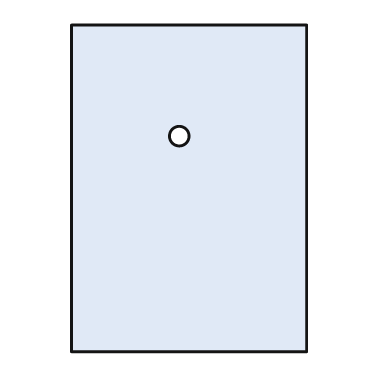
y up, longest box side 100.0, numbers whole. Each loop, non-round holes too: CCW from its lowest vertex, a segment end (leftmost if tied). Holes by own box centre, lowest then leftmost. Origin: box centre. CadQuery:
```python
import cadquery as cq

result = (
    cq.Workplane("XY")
    .moveTo(-36.0, -50.0)
    .lineTo(36.0, -50.0)
    .lineTo(36.0, 50.0)
    .lineTo(-36.0, 50.0)
    .close()
    .moveTo(-3.0, 16.0)
    .circle(3.0)
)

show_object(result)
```